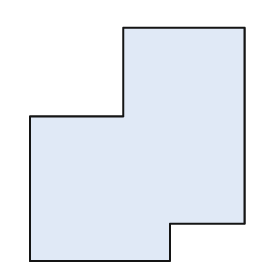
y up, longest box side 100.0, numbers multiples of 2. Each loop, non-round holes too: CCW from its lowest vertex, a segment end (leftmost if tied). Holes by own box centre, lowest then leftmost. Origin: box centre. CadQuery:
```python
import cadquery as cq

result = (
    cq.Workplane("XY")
    .moveTo(-46.0, -50.0)
    .lineTo(14.0, -50.0)
    .lineTo(14.0, -34.0)
    .lineTo(46.0, -34.0)
    .lineTo(46.0, 50.0)
    .lineTo(-6.0, 50.0)
    .lineTo(-6.0, 12.0)
    .lineTo(-46.0, 12.0)
    .close()
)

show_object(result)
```